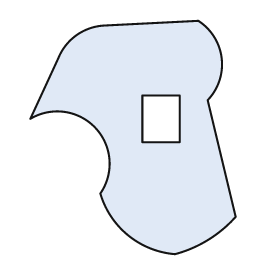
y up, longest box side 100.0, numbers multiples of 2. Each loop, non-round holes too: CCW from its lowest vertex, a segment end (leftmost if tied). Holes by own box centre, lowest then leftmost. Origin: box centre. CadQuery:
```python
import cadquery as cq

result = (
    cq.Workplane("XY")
    .moveTo(18.0, -50.0)
    .threePointArc((32.0, -44.0), (44.0, -34.0))
    .lineTo(32.0, 16.0)
    .threePointArc((38.0, 34.0), (28.0, 50.0))
    .lineTo(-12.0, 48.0)
    .threePointArc((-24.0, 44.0), (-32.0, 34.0))
    .lineTo(-44.0, 8.0)
    .threePointArc((-16.0, 4.0), (-14.0, -24.0))
    .threePointArc((-2.0, -42.0), (18.0, -50.0))
    .close()
    .moveTo(4.0, -2.0)
    .lineTo(20.0, -2.0)
    .lineTo(20.0, 18.0)
    .lineTo(4.0, 18.0)
    .close()
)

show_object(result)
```